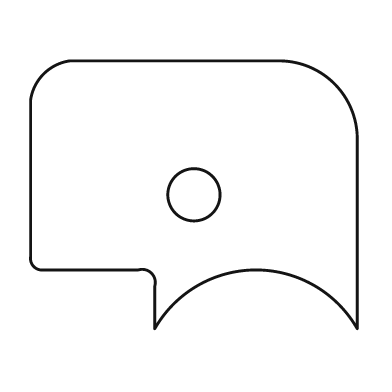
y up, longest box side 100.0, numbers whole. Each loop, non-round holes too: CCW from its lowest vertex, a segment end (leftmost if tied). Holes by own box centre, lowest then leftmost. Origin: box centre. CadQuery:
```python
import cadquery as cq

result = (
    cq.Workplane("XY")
    .moveTo(-12.0, -41.0)
    .threePointArc((19.0, -23.0), (50.0, -41.0))
    .lineTo(50.0, 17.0)
    .threePointArc((43.0, 34.0), (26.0, 41.0))
    .lineTo(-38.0, 41.0)
    .threePointArc((-46.0, 37.0), (-50.0, 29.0))
    .lineTo(-50.0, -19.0)
    .threePointArc((-49.0, -22.0), (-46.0, -23.0))
    .lineTo(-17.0, -23.0)
    .threePointArc((-13.0, -24.0), (-12.0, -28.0))
    .close()
    .moveTo(0.0, 0.0)
    .circle(8.0)
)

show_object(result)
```